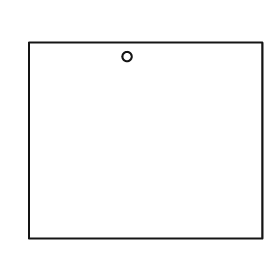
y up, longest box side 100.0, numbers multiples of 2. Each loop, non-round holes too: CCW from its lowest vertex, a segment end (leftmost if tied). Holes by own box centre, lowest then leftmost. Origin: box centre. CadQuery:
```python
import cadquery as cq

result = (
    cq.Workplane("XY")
    .moveTo(-50.0, -42.0)
    .lineTo(50.0, -42.0)
    .lineTo(50.0, 42.0)
    .lineTo(-50.0, 42.0)
    .close()
    .moveTo(-8.0, 36.0)
    .circle(2.0)
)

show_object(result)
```